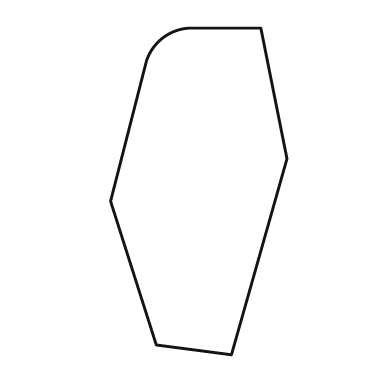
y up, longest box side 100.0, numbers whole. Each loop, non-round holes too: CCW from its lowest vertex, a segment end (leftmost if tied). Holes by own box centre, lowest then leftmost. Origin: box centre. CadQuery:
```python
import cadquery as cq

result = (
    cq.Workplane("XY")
    .moveTo(10.0, -50.0)
    .lineTo(27.0, 10.0)
    .lineTo(19.0, 50.0)
    .lineTo(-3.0, 50.0)
    .threePointArc((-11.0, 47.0), (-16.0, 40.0))
    .lineTo(-27.0, -3.0)
    .lineTo(-13.0, -47.0)
    .close()
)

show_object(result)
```